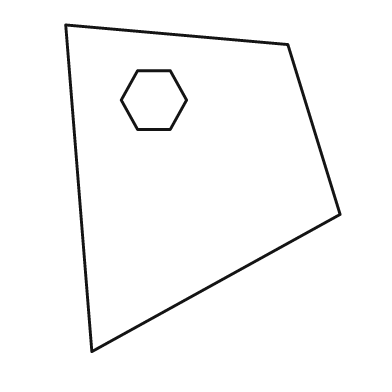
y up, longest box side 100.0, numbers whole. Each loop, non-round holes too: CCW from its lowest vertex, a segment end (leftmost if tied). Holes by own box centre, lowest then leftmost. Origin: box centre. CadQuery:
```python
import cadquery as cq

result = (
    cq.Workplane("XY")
    .moveTo(-34.0, -50.0)
    .lineTo(42.0, -8.0)
    .lineTo(26.0, 44.0)
    .lineTo(-42.0, 50.0)
    .close()
    .moveTo(-20.0, 18.0)
    .lineTo(-10.0, 18.0)
    .lineTo(-5.0, 27.0)
    .lineTo(-10.0, 36.0)
    .lineTo(-20.0, 36.0)
    .lineTo(-25.0, 27.0)
    .close()
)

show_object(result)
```